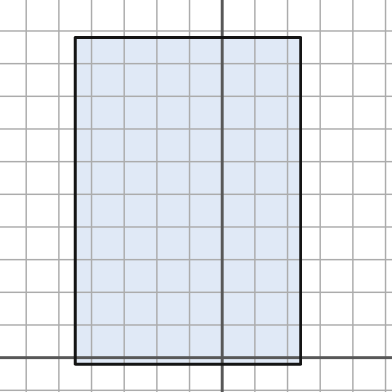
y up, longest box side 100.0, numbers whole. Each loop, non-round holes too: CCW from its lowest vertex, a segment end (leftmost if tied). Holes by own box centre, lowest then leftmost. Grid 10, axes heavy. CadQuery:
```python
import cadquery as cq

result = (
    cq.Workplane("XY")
    .moveTo(-45.0, -2.0)
    .lineTo(24.0, -2.0)
    .lineTo(24.0, 98.0)
    .lineTo(-45.0, 98.0)
    .close()
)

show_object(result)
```